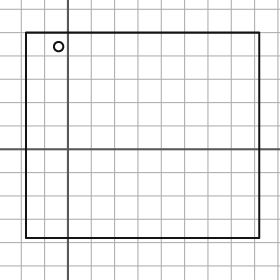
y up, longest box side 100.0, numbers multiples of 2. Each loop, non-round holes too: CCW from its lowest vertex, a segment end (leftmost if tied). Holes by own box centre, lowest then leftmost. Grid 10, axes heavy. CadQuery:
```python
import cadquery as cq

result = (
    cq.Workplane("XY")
    .moveTo(-18.0, -38.0)
    .lineTo(82.0, -38.0)
    .lineTo(82.0, 50.0)
    .lineTo(-18.0, 50.0)
    .close()
    .moveTo(-4.0, 44.0)
    .circle(2.0)
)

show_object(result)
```